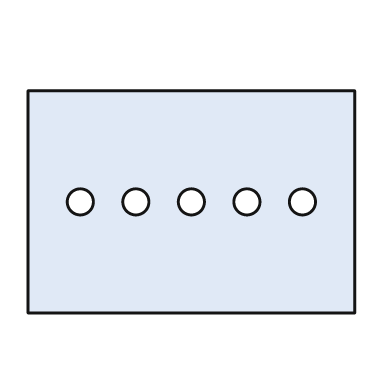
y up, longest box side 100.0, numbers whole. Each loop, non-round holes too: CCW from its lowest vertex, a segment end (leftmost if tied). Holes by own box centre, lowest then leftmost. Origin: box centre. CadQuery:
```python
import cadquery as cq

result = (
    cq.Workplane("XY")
    .moveTo(-50.0, -34.0)
    .lineTo(50.0, -34.0)
    .lineTo(50.0, 34.0)
    .lineTo(-50.0, 34.0)
    .close()
    .moveTo(-34.0, 0.0)
    .circle(4.0)
    .moveTo(-17.0, 0.0)
    .circle(4.0)
    .moveTo(0.0, 0.0)
    .circle(4.0)
    .moveTo(17.0, 0.0)
    .circle(4.0)
    .moveTo(34.0, 0.0)
    .circle(4.0)
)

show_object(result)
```